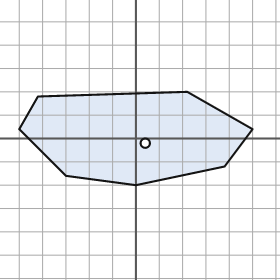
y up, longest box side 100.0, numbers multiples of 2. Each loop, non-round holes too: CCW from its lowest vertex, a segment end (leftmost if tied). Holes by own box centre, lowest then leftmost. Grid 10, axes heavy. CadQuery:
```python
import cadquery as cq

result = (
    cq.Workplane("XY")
    .moveTo(0.0, -20.0)
    .lineTo(38.0, -12.0)
    .lineTo(50.0, 4.0)
    .lineTo(22.0, 20.0)
    .lineTo(-42.0, 18.0)
    .lineTo(-50.0, 4.0)
    .lineTo(-30.0, -16.0)
    .close()
    .moveTo(4.0, -2.0)
    .circle(2.0)
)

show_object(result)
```